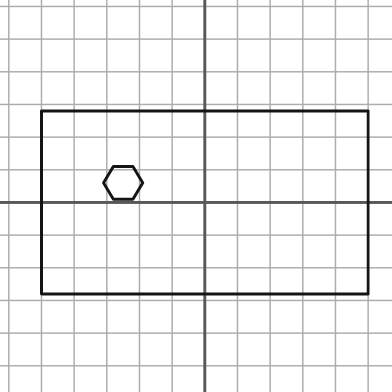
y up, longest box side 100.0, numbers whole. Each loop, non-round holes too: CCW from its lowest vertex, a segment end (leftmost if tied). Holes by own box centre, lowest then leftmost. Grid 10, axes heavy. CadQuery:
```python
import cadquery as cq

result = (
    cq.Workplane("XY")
    .moveTo(-50.0, -28.0)
    .lineTo(50.0, -28.0)
    .lineTo(50.0, 28.0)
    .lineTo(-50.0, 28.0)
    .close()
    .moveTo(-28.0, 1.0)
    .lineTo(-22.0, 1.0)
    .lineTo(-19.0, 6.0)
    .lineTo(-22.0, 11.0)
    .lineTo(-28.0, 11.0)
    .lineTo(-31.0, 6.0)
    .close()
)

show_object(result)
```